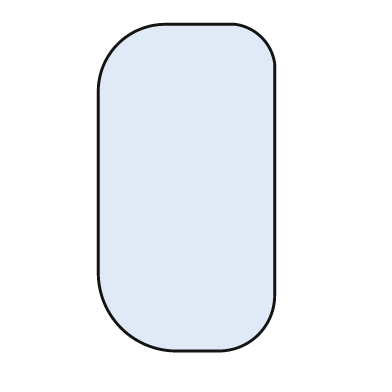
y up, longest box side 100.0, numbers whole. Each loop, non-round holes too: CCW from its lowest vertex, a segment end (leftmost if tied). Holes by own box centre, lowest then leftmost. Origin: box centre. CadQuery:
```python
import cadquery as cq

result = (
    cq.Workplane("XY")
    .moveTo(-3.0, -50.0)
    .lineTo(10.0, -50.0)
    .threePointArc((22.0, -45.0), (27.0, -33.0))
    .lineTo(27.0, 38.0)
    .threePointArc((23.0, 46.0), (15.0, 50.0))
    .lineTo(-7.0, 50.0)
    .threePointArc((-21.0, 44.0), (-27.0, 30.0))
    .lineTo(-27.0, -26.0)
    .threePointArc((-20.0, -43.0), (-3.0, -50.0))
    .close()
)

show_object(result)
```